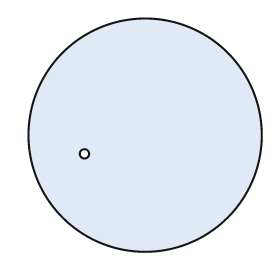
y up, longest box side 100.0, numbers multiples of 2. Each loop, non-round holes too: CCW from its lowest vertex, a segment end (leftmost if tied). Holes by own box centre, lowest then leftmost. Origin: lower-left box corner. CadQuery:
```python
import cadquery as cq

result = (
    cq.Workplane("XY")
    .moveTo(50.0, 50.0)
    .circle(50.0)
    .moveTo(24.0, 42.0)
    .circle(2.0)
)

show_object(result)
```